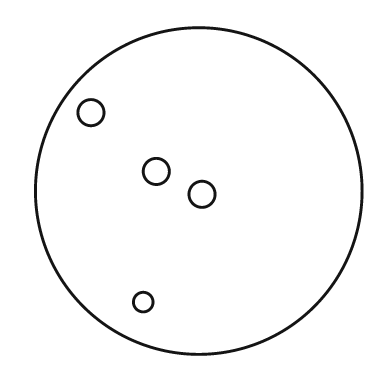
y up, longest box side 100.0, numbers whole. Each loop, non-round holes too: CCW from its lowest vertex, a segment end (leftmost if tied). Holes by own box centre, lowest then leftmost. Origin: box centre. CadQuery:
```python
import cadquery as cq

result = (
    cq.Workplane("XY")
    .moveTo(0.0, 0.0)
    .circle(50.0)
    .moveTo(-17.0, -34.0)
    .circle(3.0)
    .moveTo(1.0, -1.0)
    .circle(4.0)
    .moveTo(-13.0, 6.0)
    .circle(4.0)
    .moveTo(-33.0, 24.0)
    .circle(4.0)
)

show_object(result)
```